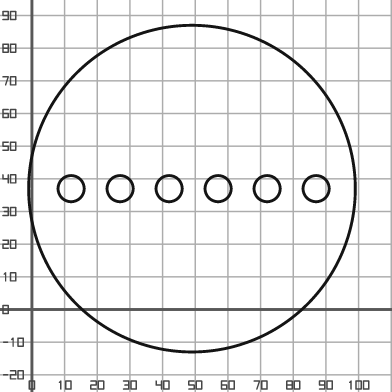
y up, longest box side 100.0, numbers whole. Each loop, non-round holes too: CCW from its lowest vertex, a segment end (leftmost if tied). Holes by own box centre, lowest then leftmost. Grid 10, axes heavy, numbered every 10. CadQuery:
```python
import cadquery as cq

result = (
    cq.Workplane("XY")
    .moveTo(49.0, 37.0)
    .circle(50.0)
    .moveTo(12.0, 37.0)
    .circle(4.0)
    .moveTo(27.0, 37.0)
    .circle(4.0)
    .moveTo(42.0, 37.0)
    .circle(4.0)
    .moveTo(57.0, 37.0)
    .circle(4.0)
    .moveTo(72.0, 37.0)
    .circle(4.0)
    .moveTo(87.0, 37.0)
    .circle(4.0)
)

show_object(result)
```